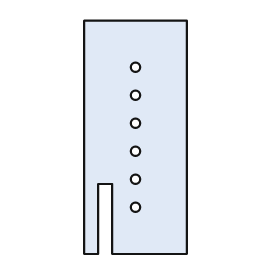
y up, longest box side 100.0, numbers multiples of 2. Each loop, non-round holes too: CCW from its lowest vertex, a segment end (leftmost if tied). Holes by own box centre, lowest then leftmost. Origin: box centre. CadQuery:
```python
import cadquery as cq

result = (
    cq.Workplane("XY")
    .moveTo(-22.0, -50.0)
    .lineTo(-16.0, -50.0)
    .lineTo(-16.0, -20.0)
    .lineTo(-10.0, -20.0)
    .lineTo(-10.0, -50.0)
    .lineTo(22.0, -50.0)
    .lineTo(22.0, 50.0)
    .lineTo(-22.0, 50.0)
    .close()
    .moveTo(0.0, -30.0)
    .circle(2.0)
    .moveTo(0.0, -18.0)
    .circle(2.0)
    .moveTo(0.0, -6.0)
    .circle(2.0)
    .moveTo(0.0, 6.0)
    .circle(2.0)
    .moveTo(0.0, 18.0)
    .circle(2.0)
    .moveTo(0.0, 30.0)
    .circle(2.0)
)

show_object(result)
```